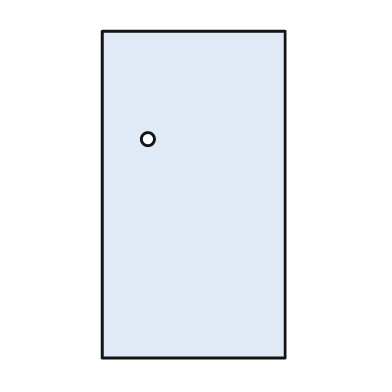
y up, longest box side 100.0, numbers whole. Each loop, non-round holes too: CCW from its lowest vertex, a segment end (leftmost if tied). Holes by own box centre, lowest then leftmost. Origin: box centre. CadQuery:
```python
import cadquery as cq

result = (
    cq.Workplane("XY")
    .moveTo(-28.0, -50.0)
    .lineTo(28.0, -50.0)
    .lineTo(28.0, 50.0)
    .lineTo(-28.0, 50.0)
    .close()
    .moveTo(-14.0, 17.0)
    .circle(2.0)
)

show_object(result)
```